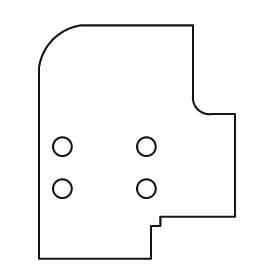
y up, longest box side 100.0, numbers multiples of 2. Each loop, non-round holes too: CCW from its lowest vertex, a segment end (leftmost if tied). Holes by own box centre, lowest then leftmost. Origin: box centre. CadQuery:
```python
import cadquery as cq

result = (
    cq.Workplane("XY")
    .moveTo(-42.0, -50.0)
    .lineTo(6.0, -50.0)
    .lineTo(6.0, -36.0)
    .lineTo(10.0, -36.0)
    .lineTo(10.0, -32.0)
    .lineTo(42.0, -32.0)
    .lineTo(42.0, 12.0)
    .lineTo(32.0, 12.0)
    .threePointArc((26.0, 14.0), (24.0, 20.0))
    .lineTo(24.0, 50.0)
    .lineTo(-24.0, 50.0)
    .threePointArc((-36.0, 44.0), (-42.0, 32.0))
    .close()
    .moveTo(-32.0, -20.0)
    .circle(4.0)
    .moveTo(4.0, -20.0)
    .circle(4.0)
    .moveTo(-32.0, -2.0)
    .circle(4.0)
    .moveTo(4.0, -2.0)
    .circle(4.0)
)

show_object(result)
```